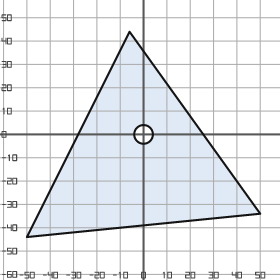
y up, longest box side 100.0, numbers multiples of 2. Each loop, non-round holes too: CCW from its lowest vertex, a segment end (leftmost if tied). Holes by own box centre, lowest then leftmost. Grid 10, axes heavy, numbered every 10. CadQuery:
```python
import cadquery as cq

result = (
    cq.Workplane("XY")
    .moveTo(-50.0, -44.0)
    .lineTo(50.0, -34.0)
    .lineTo(-6.0, 44.0)
    .close()
    .moveTo(0.0, 0.0)
    .circle(4.0)
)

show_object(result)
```